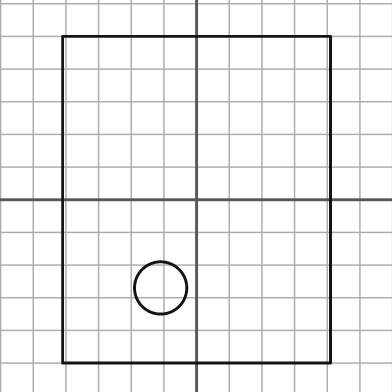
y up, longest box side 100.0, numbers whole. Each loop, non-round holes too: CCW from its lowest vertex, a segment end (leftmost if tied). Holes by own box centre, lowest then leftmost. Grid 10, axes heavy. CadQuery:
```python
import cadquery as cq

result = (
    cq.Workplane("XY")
    .moveTo(-41.0, -50.0)
    .lineTo(41.0, -50.0)
    .lineTo(41.0, 50.0)
    .lineTo(-41.0, 50.0)
    .close()
    .moveTo(-11.0, -27.0)
    .circle(8.0)
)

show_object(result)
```